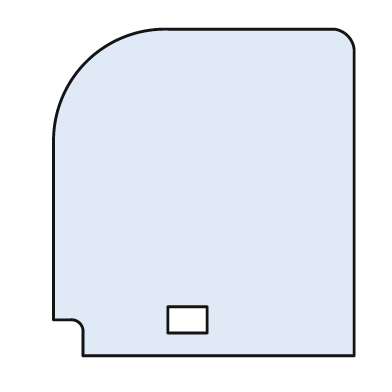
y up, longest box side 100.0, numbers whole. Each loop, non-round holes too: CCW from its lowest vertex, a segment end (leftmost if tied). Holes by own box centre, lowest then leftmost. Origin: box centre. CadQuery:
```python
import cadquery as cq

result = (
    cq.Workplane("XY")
    .moveTo(-37.0, -50.0)
    .lineTo(46.0, -50.0)
    .lineTo(46.0, 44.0)
    .threePointArc((44.0, 48.0), (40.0, 50.0))
    .lineTo(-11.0, 50.0)
    .threePointArc((-36.0, 40.0), (-46.0, 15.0))
    .lineTo(-46.0, -39.0)
    .lineTo(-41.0, -39.0)
    .threePointArc((-38.0, -40.0), (-37.0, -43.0))
    .close()
    .moveTo(-11.0, -43.0)
    .lineTo(1.0, -43.0)
    .lineTo(1.0, -35.0)
    .lineTo(-11.0, -35.0)
    .close()
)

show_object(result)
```